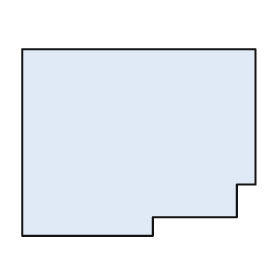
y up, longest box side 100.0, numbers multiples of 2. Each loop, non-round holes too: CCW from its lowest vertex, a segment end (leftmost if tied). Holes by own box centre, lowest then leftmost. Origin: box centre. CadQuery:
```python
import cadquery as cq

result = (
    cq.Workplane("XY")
    .moveTo(-50.0, -40.0)
    .lineTo(6.0, -40.0)
    .lineTo(6.0, -32.0)
    .lineTo(42.0, -32.0)
    .lineTo(42.0, -18.0)
    .lineTo(50.0, -18.0)
    .lineTo(50.0, 40.0)
    .lineTo(-50.0, 40.0)
    .close()
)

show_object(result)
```